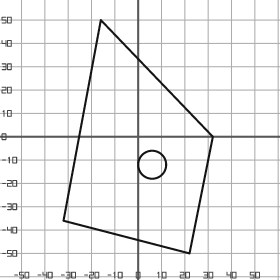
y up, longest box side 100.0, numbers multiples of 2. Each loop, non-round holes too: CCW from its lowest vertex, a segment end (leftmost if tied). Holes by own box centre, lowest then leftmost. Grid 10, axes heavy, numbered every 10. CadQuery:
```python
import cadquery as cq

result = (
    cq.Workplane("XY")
    .moveTo(22.0, -50.0)
    .lineTo(32.0, 0.0)
    .lineTo(-16.0, 50.0)
    .lineTo(-32.0, -36.0)
    .close()
    .moveTo(6.0, -12.0)
    .circle(6.0)
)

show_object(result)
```